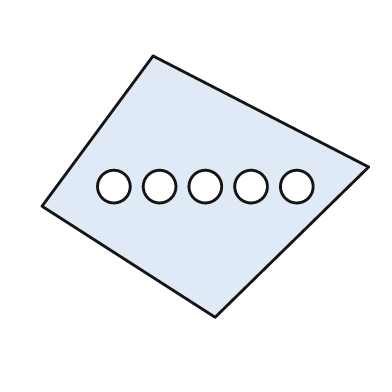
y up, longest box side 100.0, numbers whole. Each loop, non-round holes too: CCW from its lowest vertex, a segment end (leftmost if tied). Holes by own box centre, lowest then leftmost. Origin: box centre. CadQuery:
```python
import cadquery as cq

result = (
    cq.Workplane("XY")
    .moveTo(3.0, -40.0)
    .lineTo(50.0, 6.0)
    .lineTo(-16.0, 40.0)
    .lineTo(-50.0, -6.0)
    .close()
    .moveTo(-28.0, 0.0)
    .circle(5.0)
    .moveTo(-14.0, 0.0)
    .circle(5.0)
    .moveTo(0.0, 0.0)
    .circle(5.0)
    .moveTo(14.0, 0.0)
    .circle(5.0)
    .moveTo(28.0, 0.0)
    .circle(5.0)
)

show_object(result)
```